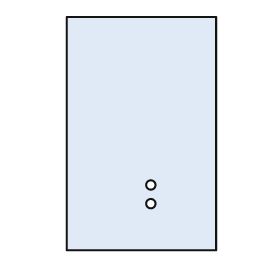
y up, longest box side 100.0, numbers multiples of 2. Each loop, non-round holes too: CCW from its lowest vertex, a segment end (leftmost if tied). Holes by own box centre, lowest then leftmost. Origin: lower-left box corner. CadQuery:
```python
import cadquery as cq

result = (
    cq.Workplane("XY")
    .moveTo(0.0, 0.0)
    .lineTo(64.0, 0.0)
    .lineTo(64.0, 100.0)
    .lineTo(0.0, 100.0)
    .close()
    .moveTo(36.0, 20.0)
    .circle(2.0)
    .moveTo(36.0, 28.0)
    .circle(2.0)
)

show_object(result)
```